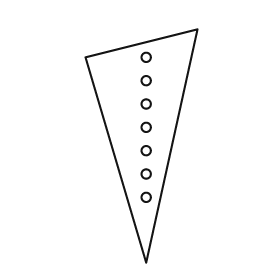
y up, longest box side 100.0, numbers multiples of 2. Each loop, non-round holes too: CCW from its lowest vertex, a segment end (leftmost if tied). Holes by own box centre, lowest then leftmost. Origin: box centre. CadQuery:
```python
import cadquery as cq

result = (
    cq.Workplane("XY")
    .moveTo(2.0, -50.0)
    .lineTo(24.0, 50.0)
    .lineTo(-24.0, 38.0)
    .close()
    .moveTo(2.0, -22.0)
    .circle(2.0)
    .moveTo(2.0, -12.0)
    .circle(2.0)
    .moveTo(2.0, -2.0)
    .circle(2.0)
    .moveTo(2.0, 8.0)
    .circle(2.0)
    .moveTo(2.0, 18.0)
    .circle(2.0)
    .moveTo(2.0, 28.0)
    .circle(2.0)
    .moveTo(2.0, 38.0)
    .circle(2.0)
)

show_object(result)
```